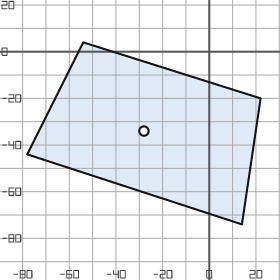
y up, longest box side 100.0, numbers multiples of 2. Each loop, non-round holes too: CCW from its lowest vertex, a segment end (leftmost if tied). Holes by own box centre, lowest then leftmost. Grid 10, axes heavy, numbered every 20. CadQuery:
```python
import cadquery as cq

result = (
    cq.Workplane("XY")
    .moveTo(14.0, -74.0)
    .lineTo(22.0, -20.0)
    .lineTo(-54.0, 4.0)
    .lineTo(-78.0, -44.0)
    .close()
    .moveTo(-28.0, -34.0)
    .circle(2.0)
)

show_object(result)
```